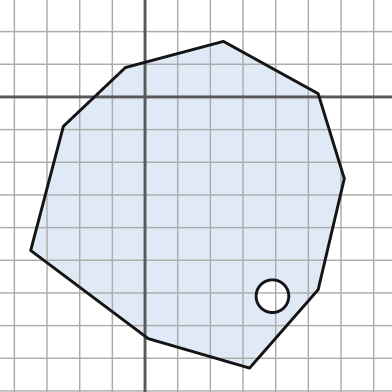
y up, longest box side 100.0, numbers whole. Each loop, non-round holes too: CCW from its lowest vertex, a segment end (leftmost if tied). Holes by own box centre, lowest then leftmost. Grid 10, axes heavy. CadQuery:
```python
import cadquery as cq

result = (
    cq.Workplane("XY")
    .moveTo(32.0, -83.0)
    .lineTo(53.0, -59.0)
    .lineTo(61.0, -25.0)
    .lineTo(53.0, 1.0)
    .lineTo(24.0, 17.0)
    .lineTo(-6.0, 9.0)
    .lineTo(-25.0, -9.0)
    .lineTo(-35.0, -47.0)
    .lineTo(1.0, -74.0)
    .close()
    .moveTo(39.0, -61.0)
    .circle(5.0)
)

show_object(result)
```